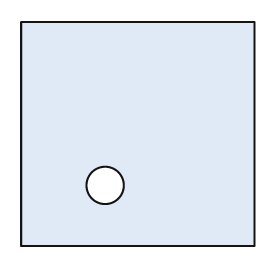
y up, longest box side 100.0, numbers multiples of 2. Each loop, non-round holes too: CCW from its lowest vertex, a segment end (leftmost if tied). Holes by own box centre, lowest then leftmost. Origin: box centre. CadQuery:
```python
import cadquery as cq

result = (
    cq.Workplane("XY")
    .moveTo(-50.0, -48.0)
    .lineTo(50.0, -48.0)
    .lineTo(50.0, 48.0)
    .lineTo(-50.0, 48.0)
    .close()
    .moveTo(-14.0, -22.0)
    .circle(8.0)
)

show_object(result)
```